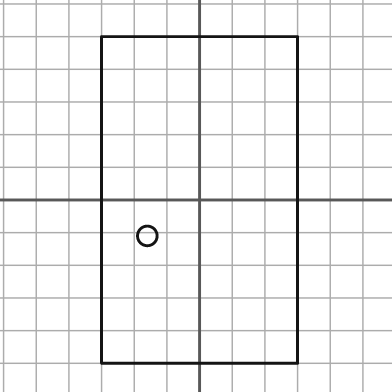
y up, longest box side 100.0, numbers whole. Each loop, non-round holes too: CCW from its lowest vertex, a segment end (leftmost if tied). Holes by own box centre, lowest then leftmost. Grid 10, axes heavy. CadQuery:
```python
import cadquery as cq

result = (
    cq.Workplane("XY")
    .moveTo(-30.0, -50.0)
    .lineTo(30.0, -50.0)
    .lineTo(30.0, 50.0)
    .lineTo(-30.0, 50.0)
    .close()
    .moveTo(-16.0, -11.0)
    .circle(3.0)
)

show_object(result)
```